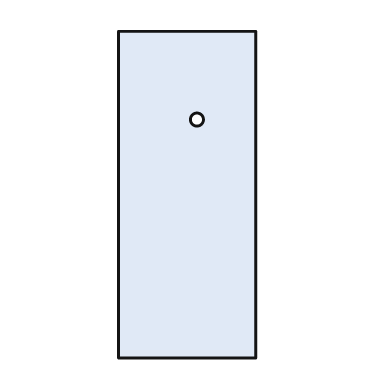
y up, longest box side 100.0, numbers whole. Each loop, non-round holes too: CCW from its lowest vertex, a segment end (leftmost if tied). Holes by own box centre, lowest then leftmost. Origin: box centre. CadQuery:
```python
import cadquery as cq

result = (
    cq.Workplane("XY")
    .moveTo(-21.0, -50.0)
    .lineTo(21.0, -50.0)
    .lineTo(21.0, 50.0)
    .lineTo(-21.0, 50.0)
    .close()
    .moveTo(3.0, 23.0)
    .circle(2.0)
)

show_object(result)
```